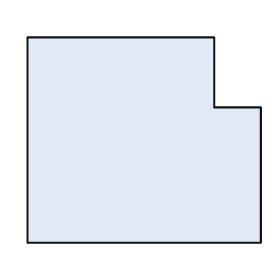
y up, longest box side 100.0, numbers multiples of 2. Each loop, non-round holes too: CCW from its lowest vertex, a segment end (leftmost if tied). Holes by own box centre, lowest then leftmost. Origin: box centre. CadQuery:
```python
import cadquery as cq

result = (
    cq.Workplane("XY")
    .moveTo(-50.0, -44.0)
    .lineTo(50.0, -44.0)
    .lineTo(50.0, 14.0)
    .lineTo(30.0, 14.0)
    .lineTo(30.0, 44.0)
    .lineTo(-50.0, 44.0)
    .close()
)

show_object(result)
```